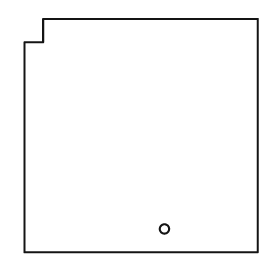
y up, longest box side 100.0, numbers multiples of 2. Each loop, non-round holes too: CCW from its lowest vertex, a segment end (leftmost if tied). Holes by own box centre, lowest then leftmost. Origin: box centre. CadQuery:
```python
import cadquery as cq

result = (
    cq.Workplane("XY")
    .moveTo(-50.0, -50.0)
    .lineTo(50.0, -50.0)
    .lineTo(50.0, 50.0)
    .lineTo(-42.0, 50.0)
    .lineTo(-42.0, 40.0)
    .lineTo(-50.0, 40.0)
    .close()
    .moveTo(10.0, -40.0)
    .circle(2.0)
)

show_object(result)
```